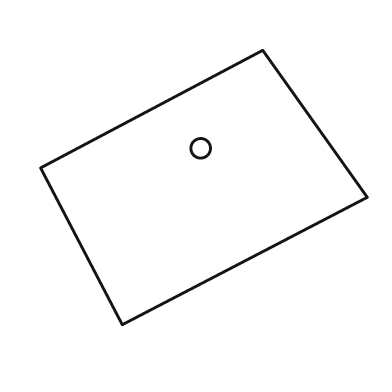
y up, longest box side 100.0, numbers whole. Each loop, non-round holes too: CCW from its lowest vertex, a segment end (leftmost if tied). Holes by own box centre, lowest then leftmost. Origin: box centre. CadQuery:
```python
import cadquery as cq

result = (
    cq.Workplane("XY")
    .moveTo(-25.0, -42.0)
    .lineTo(50.0, -3.0)
    .lineTo(18.0, 42.0)
    .lineTo(-50.0, 6.0)
    .close()
    .moveTo(-1.0, 12.0)
    .circle(3.0)
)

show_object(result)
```